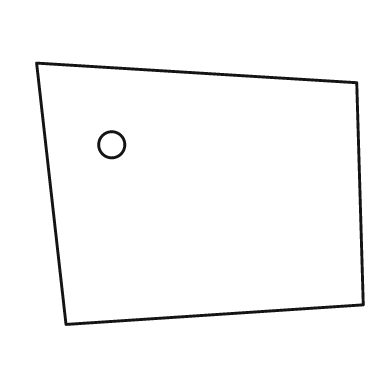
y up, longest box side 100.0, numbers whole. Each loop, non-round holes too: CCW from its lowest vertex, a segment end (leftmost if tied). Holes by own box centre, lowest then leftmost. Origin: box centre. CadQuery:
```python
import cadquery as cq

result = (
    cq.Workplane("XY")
    .moveTo(-41.0, -40.0)
    .lineTo(50.0, -34.0)
    .lineTo(48.0, 34.0)
    .lineTo(-50.0, 40.0)
    .close()
    .moveTo(-27.0, 15.0)
    .circle(4.0)
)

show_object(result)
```